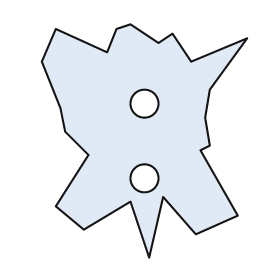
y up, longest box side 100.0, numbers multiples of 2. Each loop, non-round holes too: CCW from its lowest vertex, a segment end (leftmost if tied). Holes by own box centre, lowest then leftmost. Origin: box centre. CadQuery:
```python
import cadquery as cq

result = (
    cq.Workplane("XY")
    .moveTo(2.0, -50.0)
    .lineTo(8.0, -24.0)
    .lineTo(22.0, -40.0)
    .lineTo(40.0, -32.0)
    .lineTo(24.0, -4.0)
    .lineTo(28.0, -2.0)
    .lineTo(26.0, 10.0)
    .lineTo(28.0, 22.0)
    .lineTo(44.0, 44.0)
    .lineTo(20.0, 34.0)
    .lineTo(12.0, 46.0)
    .lineTo(6.0, 42.0)
    .lineTo(-6.0, 50.0)
    .lineTo(-12.0, 48.0)
    .lineTo(-16.0, 38.0)
    .lineTo(-38.0, 48.0)
    .lineTo(-44.0, 34.0)
    .lineTo(-36.0, 14.0)
    .lineTo(-34.0, 4.0)
    .lineTo(-24.0, -6.0)
    .lineTo(-38.0, -28.0)
    .lineTo(-26.0, -38.0)
    .lineTo(-6.0, -26.0)
    .close()
    .moveTo(0.0, -16.0)
    .circle(6.0)
    .moveTo(0.0, 16.0)
    .circle(6.0)
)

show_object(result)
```